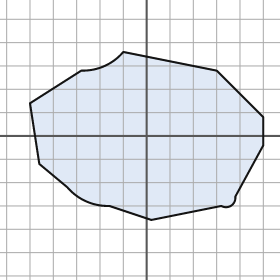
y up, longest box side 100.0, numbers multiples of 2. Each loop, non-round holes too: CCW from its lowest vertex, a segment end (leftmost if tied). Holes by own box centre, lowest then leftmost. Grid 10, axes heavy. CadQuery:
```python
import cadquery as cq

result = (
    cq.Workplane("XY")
    .moveTo(2.0, -36.0)
    .lineTo(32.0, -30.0)
    .threePointArc((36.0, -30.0), (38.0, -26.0))
    .lineTo(50.0, -4.0)
    .lineTo(50.0, 8.0)
    .lineTo(30.0, 28.0)
    .lineTo(-10.0, 36.0)
    .threePointArc((-18.0, 30.0), (-28.0, 28.0))
    .lineTo(-50.0, 14.0)
    .lineTo(-46.0, -12.0)
    .lineTo(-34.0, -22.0)
    .threePointArc((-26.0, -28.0), (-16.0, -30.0))
    .close()
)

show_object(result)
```